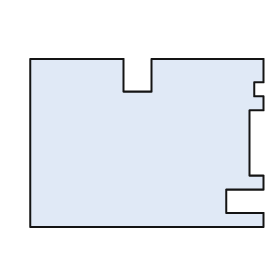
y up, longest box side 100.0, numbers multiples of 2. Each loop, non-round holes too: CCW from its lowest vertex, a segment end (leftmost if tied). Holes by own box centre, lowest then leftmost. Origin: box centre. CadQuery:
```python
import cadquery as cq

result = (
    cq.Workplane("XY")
    .moveTo(-50.0, -36.0)
    .lineTo(50.0, -36.0)
    .lineTo(50.0, -30.0)
    .lineTo(34.0, -30.0)
    .lineTo(34.0, -20.0)
    .lineTo(50.0, -20.0)
    .lineTo(50.0, -14.0)
    .lineTo(44.0, -14.0)
    .lineTo(44.0, 14.0)
    .lineTo(50.0, 14.0)
    .lineTo(50.0, 20.0)
    .lineTo(46.0, 20.0)
    .lineTo(46.0, 26.0)
    .lineTo(50.0, 26.0)
    .lineTo(50.0, 36.0)
    .lineTo(2.0, 36.0)
    .lineTo(2.0, 22.0)
    .lineTo(-10.0, 22.0)
    .lineTo(-10.0, 36.0)
    .lineTo(-50.0, 36.0)
    .close()
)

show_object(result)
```